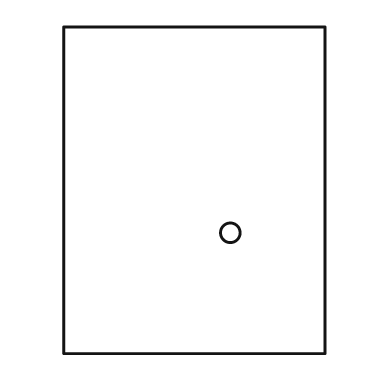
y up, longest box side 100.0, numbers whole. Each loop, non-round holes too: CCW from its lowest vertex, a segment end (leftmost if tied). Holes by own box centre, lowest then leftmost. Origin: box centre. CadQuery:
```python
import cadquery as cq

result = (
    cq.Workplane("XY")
    .moveTo(-40.0, -50.0)
    .lineTo(40.0, -50.0)
    .lineTo(40.0, 50.0)
    .lineTo(-40.0, 50.0)
    .close()
    .moveTo(11.0, -13.0)
    .circle(3.0)
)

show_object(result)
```